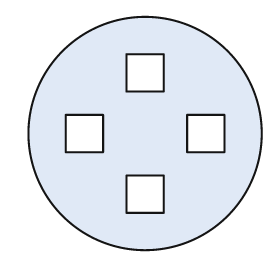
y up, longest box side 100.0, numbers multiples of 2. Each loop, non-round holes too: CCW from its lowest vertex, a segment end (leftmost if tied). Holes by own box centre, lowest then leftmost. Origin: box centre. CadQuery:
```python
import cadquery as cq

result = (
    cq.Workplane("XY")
    .moveTo(0.0, 0.0)
    .circle(50.0)
    .moveTo(-8.0, -34.0)
    .lineTo(8.0, -34.0)
    .lineTo(8.0, -18.0)
    .lineTo(-8.0, -18.0)
    .close()
    .moveTo(-34.0, -8.0)
    .lineTo(-18.0, -8.0)
    .lineTo(-18.0, 8.0)
    .lineTo(-34.0, 8.0)
    .close()
    .moveTo(18.0, -8.0)
    .lineTo(34.0, -8.0)
    .lineTo(34.0, 8.0)
    .lineTo(18.0, 8.0)
    .close()
    .moveTo(-8.0, 18.0)
    .lineTo(8.0, 18.0)
    .lineTo(8.0, 34.0)
    .lineTo(-8.0, 34.0)
    .close()
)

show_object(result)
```